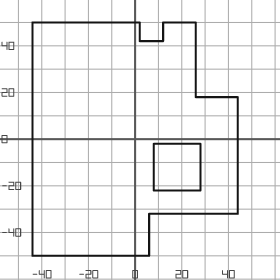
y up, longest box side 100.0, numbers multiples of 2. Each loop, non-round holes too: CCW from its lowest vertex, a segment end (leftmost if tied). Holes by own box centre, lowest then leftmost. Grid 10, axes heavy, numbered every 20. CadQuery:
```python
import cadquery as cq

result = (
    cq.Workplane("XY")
    .moveTo(-44.0, -50.0)
    .lineTo(6.0, -50.0)
    .lineTo(6.0, -32.0)
    .lineTo(44.0, -32.0)
    .lineTo(44.0, 18.0)
    .lineTo(26.0, 18.0)
    .lineTo(26.0, 50.0)
    .lineTo(12.0, 50.0)
    .lineTo(12.0, 42.0)
    .lineTo(2.0, 42.0)
    .lineTo(2.0, 50.0)
    .lineTo(-44.0, 50.0)
    .close()
    .moveTo(8.0, -22.0)
    .lineTo(28.0, -22.0)
    .lineTo(28.0, -2.0)
    .lineTo(8.0, -2.0)
    .close()
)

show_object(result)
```